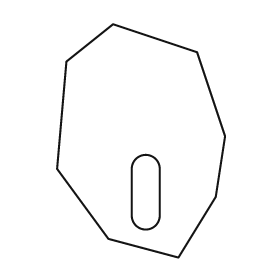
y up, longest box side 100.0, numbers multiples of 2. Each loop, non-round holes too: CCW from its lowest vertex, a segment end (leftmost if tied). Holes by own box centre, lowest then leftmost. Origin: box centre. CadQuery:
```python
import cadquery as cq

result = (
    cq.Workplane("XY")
    .moveTo(16.0, -50.0)
    .lineTo(32.0, -24.0)
    .lineTo(36.0, 2.0)
    .lineTo(24.0, 38.0)
    .lineTo(-12.0, 50.0)
    .lineTo(-32.0, 34.0)
    .lineTo(-36.0, -12.0)
    .lineTo(-14.0, -42.0)
    .close()
    .moveTo(-4.0, -32.0)
    .threePointArc((2.0, -38.0), (8.0, -32.0))
    .lineTo(8.0, -12.0)
    .threePointArc((2.0, -6.0), (-4.0, -12.0))
    .close()
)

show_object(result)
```